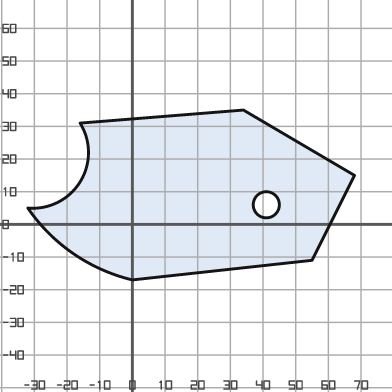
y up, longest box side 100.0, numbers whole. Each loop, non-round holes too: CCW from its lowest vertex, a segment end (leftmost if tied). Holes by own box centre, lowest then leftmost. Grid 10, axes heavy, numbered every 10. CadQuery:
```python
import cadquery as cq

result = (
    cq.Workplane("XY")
    .moveTo(0.0, -17.0)
    .lineTo(55.0, -11.0)
    .lineTo(68.0, 15.0)
    .lineTo(34.0, 35.0)
    .lineTo(-16.0, 31.0)
    .threePointArc((-16.0, 13.0), (-32.0, 5.0))
    .threePointArc((-18.0, -9.0), (0.0, -17.0))
    .close()
    .moveTo(41.0, 6.0)
    .circle(4.0)
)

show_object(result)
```